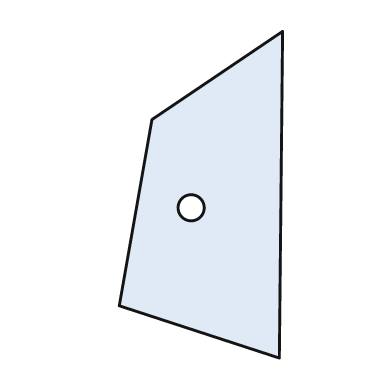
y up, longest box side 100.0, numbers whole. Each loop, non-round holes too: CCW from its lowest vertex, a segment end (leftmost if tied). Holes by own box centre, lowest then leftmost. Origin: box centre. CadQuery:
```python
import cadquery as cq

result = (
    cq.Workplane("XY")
    .moveTo(24.0, -50.0)
    .lineTo(25.0, 50.0)
    .lineTo(-15.0, 23.0)
    .lineTo(-25.0, -34.0)
    .close()
    .moveTo(-3.0, -4.0)
    .circle(4.0)
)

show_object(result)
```